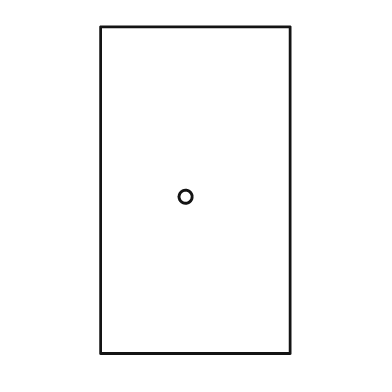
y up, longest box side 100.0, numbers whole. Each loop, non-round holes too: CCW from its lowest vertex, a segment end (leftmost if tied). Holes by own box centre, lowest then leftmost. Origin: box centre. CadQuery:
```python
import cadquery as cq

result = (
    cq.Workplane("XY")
    .moveTo(-29.0, -50.0)
    .lineTo(29.0, -50.0)
    .lineTo(29.0, 50.0)
    .lineTo(-29.0, 50.0)
    .close()
    .moveTo(-3.0, -2.0)
    .circle(2.0)
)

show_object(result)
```